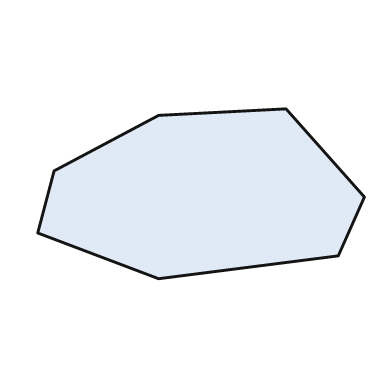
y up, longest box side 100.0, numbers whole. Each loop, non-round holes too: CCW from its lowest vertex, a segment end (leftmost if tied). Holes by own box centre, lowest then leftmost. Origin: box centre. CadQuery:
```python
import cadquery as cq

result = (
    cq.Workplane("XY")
    .moveTo(-13.0, -26.0)
    .lineTo(42.0, -19.0)
    .lineTo(50.0, -1.0)
    .lineTo(26.0, 26.0)
    .lineTo(-13.0, 24.0)
    .lineTo(-45.0, 7.0)
    .lineTo(-50.0, -12.0)
    .close()
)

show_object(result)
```